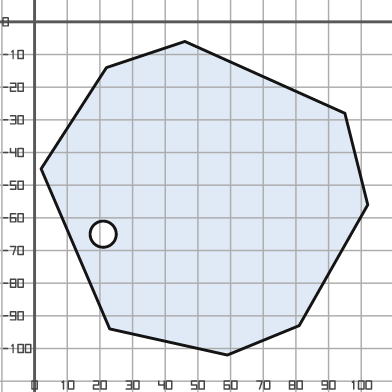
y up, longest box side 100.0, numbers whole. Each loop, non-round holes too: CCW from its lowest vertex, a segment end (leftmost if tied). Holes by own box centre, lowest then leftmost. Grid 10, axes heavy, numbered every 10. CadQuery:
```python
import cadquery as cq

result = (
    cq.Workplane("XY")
    .moveTo(59.0, -102.0)
    .lineTo(81.0, -93.0)
    .lineTo(102.0, -56.0)
    .lineTo(95.0, -28.0)
    .lineTo(46.0, -6.0)
    .lineTo(22.0, -14.0)
    .lineTo(2.0, -45.0)
    .lineTo(23.0, -94.0)
    .close()
    .moveTo(21.0, -65.0)
    .circle(4.0)
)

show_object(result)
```